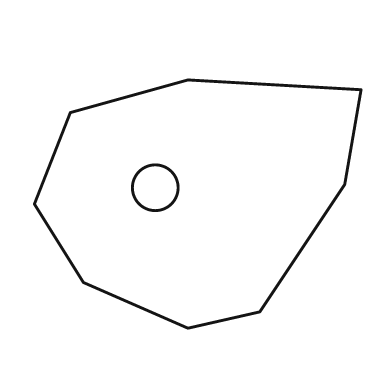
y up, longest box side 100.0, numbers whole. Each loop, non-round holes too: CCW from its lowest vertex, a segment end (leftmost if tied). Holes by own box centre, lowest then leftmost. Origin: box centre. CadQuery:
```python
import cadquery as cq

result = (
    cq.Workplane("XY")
    .moveTo(-3.0, -38.0)
    .lineTo(19.0, -33.0)
    .lineTo(45.0, 6.0)
    .lineTo(50.0, 35.0)
    .lineTo(-3.0, 38.0)
    .lineTo(-39.0, 28.0)
    .lineTo(-50.0, 0.0)
    .lineTo(-35.0, -24.0)
    .close()
    .moveTo(-13.0, 5.0)
    .circle(7.0)
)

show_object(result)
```